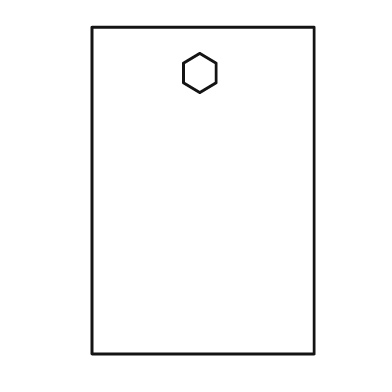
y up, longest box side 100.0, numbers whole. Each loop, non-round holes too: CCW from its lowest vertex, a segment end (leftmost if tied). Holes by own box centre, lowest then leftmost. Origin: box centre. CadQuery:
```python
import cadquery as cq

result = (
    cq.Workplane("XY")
    .moveTo(-34.0, -50.0)
    .lineTo(34.0, -50.0)
    .lineTo(34.0, 50.0)
    .lineTo(-34.0, 50.0)
    .close()
    .moveTo(-1.0, 30.0)
    .lineTo(4.0, 33.0)
    .lineTo(4.0, 39.0)
    .lineTo(-1.0, 42.0)
    .lineTo(-6.0, 39.0)
    .lineTo(-6.0, 33.0)
    .close()
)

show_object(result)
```